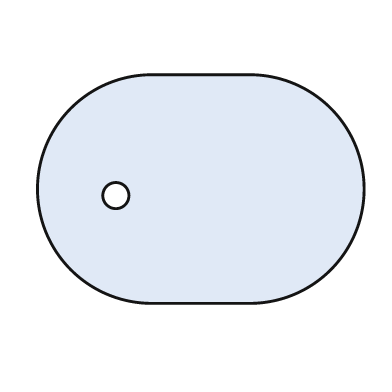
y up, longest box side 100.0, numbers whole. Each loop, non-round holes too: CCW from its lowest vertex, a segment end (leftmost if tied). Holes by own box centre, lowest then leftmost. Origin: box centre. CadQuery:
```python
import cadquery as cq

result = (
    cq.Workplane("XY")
    .moveTo(-15.0, -35.0)
    .lineTo(15.0, -35.0)
    .threePointArc((50.0, 0.0), (15.0, 35.0))
    .lineTo(-15.0, 35.0)
    .threePointArc((-50.0, 0.0), (-15.0, -35.0))
    .close()
    .moveTo(-26.0, -2.0)
    .circle(4.0)
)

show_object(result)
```